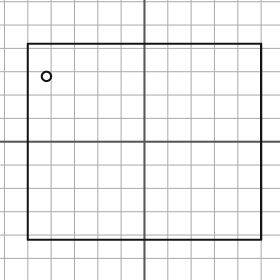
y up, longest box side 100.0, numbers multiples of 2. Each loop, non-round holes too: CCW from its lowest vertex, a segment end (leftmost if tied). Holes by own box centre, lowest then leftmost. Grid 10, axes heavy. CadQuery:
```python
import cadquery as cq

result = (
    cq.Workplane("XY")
    .moveTo(-50.0, -42.0)
    .lineTo(50.0, -42.0)
    .lineTo(50.0, 42.0)
    .lineTo(-50.0, 42.0)
    .close()
    .moveTo(-42.0, 28.0)
    .circle(2.0)
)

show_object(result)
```